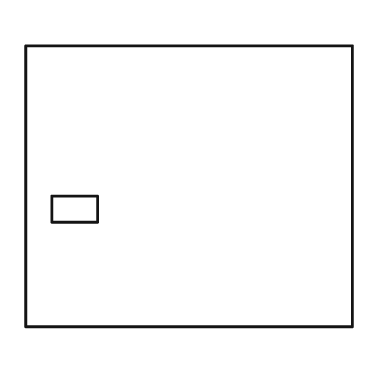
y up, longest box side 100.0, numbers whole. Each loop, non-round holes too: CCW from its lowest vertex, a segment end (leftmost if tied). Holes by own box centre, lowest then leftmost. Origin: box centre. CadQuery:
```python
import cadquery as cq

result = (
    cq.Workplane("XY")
    .moveTo(-50.0, -43.0)
    .lineTo(50.0, -43.0)
    .lineTo(50.0, 43.0)
    .lineTo(-50.0, 43.0)
    .close()
    .moveTo(-42.0, -11.0)
    .lineTo(-28.0, -11.0)
    .lineTo(-28.0, -3.0)
    .lineTo(-42.0, -3.0)
    .close()
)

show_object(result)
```